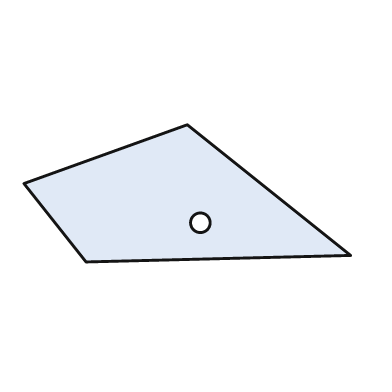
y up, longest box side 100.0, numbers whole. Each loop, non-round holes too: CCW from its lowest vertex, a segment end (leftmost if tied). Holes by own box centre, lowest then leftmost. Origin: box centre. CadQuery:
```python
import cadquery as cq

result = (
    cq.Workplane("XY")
    .moveTo(-31.0, -21.0)
    .lineTo(50.0, -19.0)
    .lineTo(0.0, 21.0)
    .lineTo(-50.0, 3.0)
    .close()
    .moveTo(4.0, -9.0)
    .circle(3.0)
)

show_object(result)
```